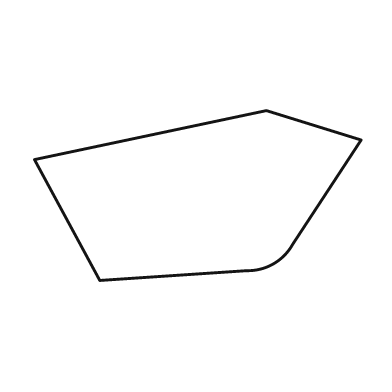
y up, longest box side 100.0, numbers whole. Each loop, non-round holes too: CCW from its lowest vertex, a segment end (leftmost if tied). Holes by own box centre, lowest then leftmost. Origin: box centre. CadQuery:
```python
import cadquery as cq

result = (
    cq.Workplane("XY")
    .moveTo(-30.0, -26.0)
    .lineTo(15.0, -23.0)
    .threePointArc((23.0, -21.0), (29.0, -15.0))
    .lineTo(50.0, 17.0)
    .lineTo(21.0, 26.0)
    .lineTo(-50.0, 11.0)
    .close()
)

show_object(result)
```